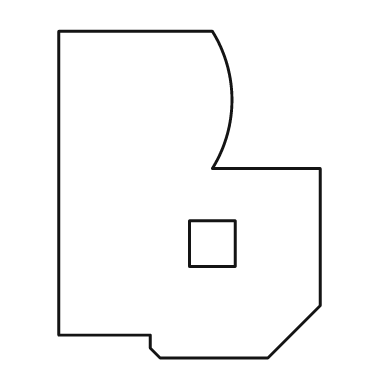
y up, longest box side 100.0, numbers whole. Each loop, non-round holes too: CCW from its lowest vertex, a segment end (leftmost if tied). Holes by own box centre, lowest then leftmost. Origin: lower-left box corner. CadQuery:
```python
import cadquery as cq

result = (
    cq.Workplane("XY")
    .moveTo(31.0, 0.0)
    .lineTo(64.0, 0.0)
    .lineTo(80.0, 16.0)
    .lineTo(80.0, 58.0)
    .lineTo(47.0, 58.0)
    .threePointArc((53.0, 79.0), (47.0, 100.0))
    .lineTo(0.0, 100.0)
    .lineTo(0.0, 7.0)
    .lineTo(28.0, 7.0)
    .lineTo(28.0, 3.0)
    .close()
    .moveTo(40.0, 28.0)
    .lineTo(54.0, 28.0)
    .lineTo(54.0, 42.0)
    .lineTo(40.0, 42.0)
    .close()
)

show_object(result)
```